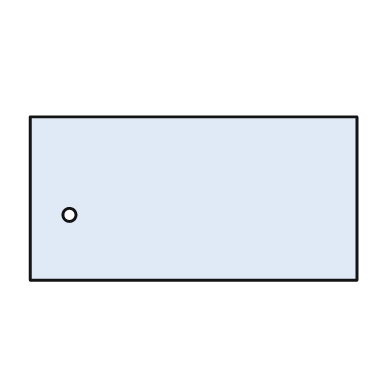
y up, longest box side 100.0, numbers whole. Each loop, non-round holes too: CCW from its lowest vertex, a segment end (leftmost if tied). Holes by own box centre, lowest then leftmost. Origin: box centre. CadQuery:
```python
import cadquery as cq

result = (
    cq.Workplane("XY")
    .moveTo(-50.0, -25.0)
    .lineTo(50.0, -25.0)
    .lineTo(50.0, 25.0)
    .lineTo(-50.0, 25.0)
    .close()
    .moveTo(-38.0, -5.0)
    .circle(2.0)
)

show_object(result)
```